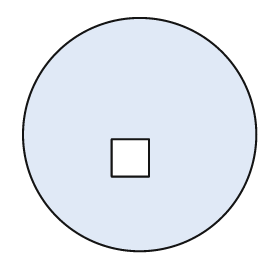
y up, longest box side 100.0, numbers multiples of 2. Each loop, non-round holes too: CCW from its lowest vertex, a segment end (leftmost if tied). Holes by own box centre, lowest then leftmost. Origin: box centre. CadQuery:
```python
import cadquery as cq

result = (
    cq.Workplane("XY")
    .moveTo(0.0, 0.0)
    .circle(50.0)
    .moveTo(-12.0, -18.0)
    .lineTo(4.0, -18.0)
    .lineTo(4.0, -2.0)
    .lineTo(-12.0, -2.0)
    .close()
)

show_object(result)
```